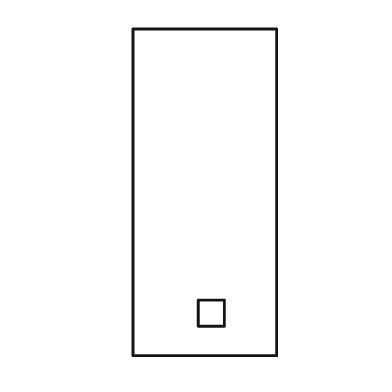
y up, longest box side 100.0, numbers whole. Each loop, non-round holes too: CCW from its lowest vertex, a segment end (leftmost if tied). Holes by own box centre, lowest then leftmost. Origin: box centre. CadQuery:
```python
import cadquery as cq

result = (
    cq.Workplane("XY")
    .moveTo(-22.0, -50.0)
    .lineTo(22.0, -50.0)
    .lineTo(22.0, 50.0)
    .lineTo(-22.0, 50.0)
    .close()
    .moveTo(-2.0, -41.0)
    .lineTo(6.0, -41.0)
    .lineTo(6.0, -33.0)
    .lineTo(-2.0, -33.0)
    .close()
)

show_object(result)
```